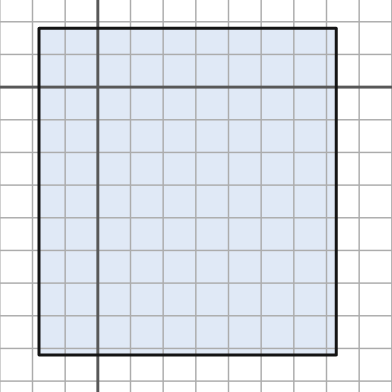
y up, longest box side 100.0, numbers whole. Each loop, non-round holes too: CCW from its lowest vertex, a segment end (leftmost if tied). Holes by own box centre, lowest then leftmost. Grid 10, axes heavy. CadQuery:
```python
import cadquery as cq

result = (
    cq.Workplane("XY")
    .moveTo(-18.0, -82.0)
    .lineTo(73.0, -82.0)
    .lineTo(73.0, 18.0)
    .lineTo(-18.0, 18.0)
    .close()
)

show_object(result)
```